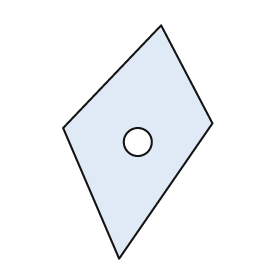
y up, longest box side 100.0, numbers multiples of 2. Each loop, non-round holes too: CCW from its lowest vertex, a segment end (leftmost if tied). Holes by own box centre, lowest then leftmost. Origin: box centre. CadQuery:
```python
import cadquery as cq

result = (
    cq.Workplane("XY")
    .moveTo(-8.0, -50.0)
    .lineTo(32.0, 8.0)
    .lineTo(10.0, 50.0)
    .lineTo(-32.0, 6.0)
    .close()
    .moveTo(0.0, 0.0)
    .circle(6.0)
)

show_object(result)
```